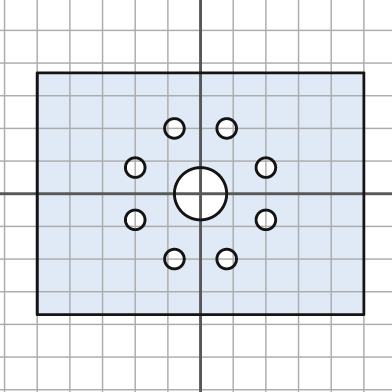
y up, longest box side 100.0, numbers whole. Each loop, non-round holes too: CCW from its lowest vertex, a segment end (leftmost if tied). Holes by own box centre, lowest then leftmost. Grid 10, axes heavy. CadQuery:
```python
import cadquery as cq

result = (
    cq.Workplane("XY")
    .moveTo(-50.0, -37.0)
    .lineTo(50.0, -37.0)
    .lineTo(50.0, 37.0)
    .lineTo(-50.0, 37.0)
    .close()
    .moveTo(-8.0, -20.0)
    .circle(3.0)
    .moveTo(8.0, -20.0)
    .circle(3.0)
    .moveTo(-20.0, -8.0)
    .circle(3.0)
    .moveTo(20.0, -8.0)
    .circle(3.0)
    .moveTo(0.0, 0.0)
    .circle(8.0)
    .moveTo(-20.0, 8.0)
    .circle(3.0)
    .moveTo(20.0, 8.0)
    .circle(3.0)
    .moveTo(-8.0, 20.0)
    .circle(3.0)
    .moveTo(8.0, 20.0)
    .circle(3.0)
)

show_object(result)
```